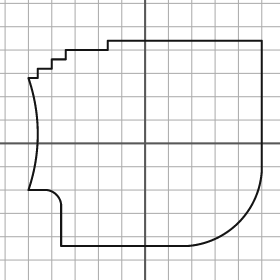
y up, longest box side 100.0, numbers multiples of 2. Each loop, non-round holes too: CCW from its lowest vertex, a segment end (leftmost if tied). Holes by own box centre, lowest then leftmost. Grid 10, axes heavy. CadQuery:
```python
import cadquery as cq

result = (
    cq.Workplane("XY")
    .moveTo(-36.0, -44.0)
    .lineTo(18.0, -44.0)
    .threePointArc((40.0, -34.0), (50.0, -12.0))
    .lineTo(50.0, 44.0)
    .lineTo(-16.0, 44.0)
    .lineTo(-16.0, 40.0)
    .lineTo(-34.0, 40.0)
    .lineTo(-34.0, 36.0)
    .lineTo(-40.0, 36.0)
    .lineTo(-40.0, 32.0)
    .lineTo(-46.0, 32.0)
    .lineTo(-46.0, 28.0)
    .lineTo(-50.0, 28.0)
    .threePointArc((-46.0, 4.0), (-50.0, -20.0))
    .lineTo(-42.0, -20.0)
    .threePointArc((-38.0, -22.0), (-36.0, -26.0))
    .close()
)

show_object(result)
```